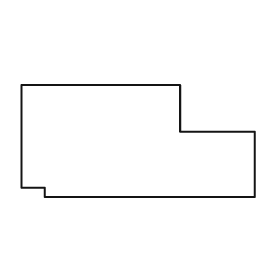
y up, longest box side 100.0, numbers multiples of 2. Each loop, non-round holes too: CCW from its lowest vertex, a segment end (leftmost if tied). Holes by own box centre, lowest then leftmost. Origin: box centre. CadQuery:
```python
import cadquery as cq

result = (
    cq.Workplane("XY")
    .moveTo(-40.0, -24.0)
    .lineTo(50.0, -24.0)
    .lineTo(50.0, 4.0)
    .lineTo(18.0, 4.0)
    .lineTo(18.0, 24.0)
    .lineTo(-50.0, 24.0)
    .lineTo(-50.0, -20.0)
    .lineTo(-40.0, -20.0)
    .close()
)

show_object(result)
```